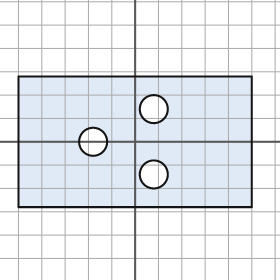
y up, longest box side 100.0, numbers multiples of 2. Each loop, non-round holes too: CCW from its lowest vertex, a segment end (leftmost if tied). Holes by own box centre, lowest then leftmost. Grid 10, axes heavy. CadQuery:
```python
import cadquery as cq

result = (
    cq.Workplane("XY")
    .moveTo(-50.0, -28.0)
    .lineTo(50.0, -28.0)
    .lineTo(50.0, 28.0)
    .lineTo(-50.0, 28.0)
    .close()
    .moveTo(8.0, -14.0)
    .circle(6.0)
    .moveTo(-18.0, 0.0)
    .circle(6.0)
    .moveTo(8.0, 14.0)
    .circle(6.0)
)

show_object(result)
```